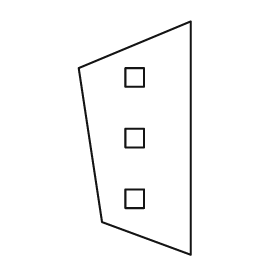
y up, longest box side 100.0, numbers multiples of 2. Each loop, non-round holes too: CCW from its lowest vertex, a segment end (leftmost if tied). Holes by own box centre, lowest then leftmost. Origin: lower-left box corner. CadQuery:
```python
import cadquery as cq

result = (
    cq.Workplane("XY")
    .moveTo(48.0, 0.0)
    .lineTo(48.0, 100.0)
    .lineTo(0.0, 80.0)
    .lineTo(10.0, 14.0)
    .close()
    .moveTo(20.0, 20.0)
    .lineTo(28.0, 20.0)
    .lineTo(28.0, 28.0)
    .lineTo(20.0, 28.0)
    .close()
    .moveTo(20.0, 46.0)
    .lineTo(28.0, 46.0)
    .lineTo(28.0, 54.0)
    .lineTo(20.0, 54.0)
    .close()
    .moveTo(20.0, 72.0)
    .lineTo(28.0, 72.0)
    .lineTo(28.0, 80.0)
    .lineTo(20.0, 80.0)
    .close()
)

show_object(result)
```